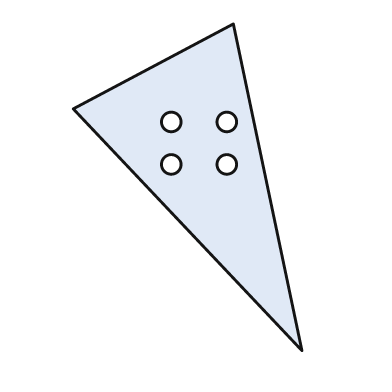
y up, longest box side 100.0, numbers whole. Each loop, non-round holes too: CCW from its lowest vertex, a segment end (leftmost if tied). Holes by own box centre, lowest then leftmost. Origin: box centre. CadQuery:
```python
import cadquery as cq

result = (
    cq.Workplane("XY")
    .moveTo(35.0, -50.0)
    .lineTo(14.0, 50.0)
    .lineTo(-35.0, 24.0)
    .close()
    .moveTo(-5.0, 7.0)
    .circle(3.0)
    .moveTo(12.0, 7.0)
    .circle(3.0)
    .moveTo(-5.0, 20.0)
    .circle(3.0)
    .moveTo(12.0, 20.0)
    .circle(3.0)
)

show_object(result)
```